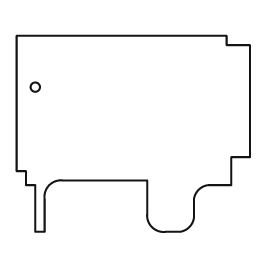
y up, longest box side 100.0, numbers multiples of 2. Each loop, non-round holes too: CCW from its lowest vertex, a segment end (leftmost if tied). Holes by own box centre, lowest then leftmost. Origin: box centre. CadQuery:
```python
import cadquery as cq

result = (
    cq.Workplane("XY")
    .moveTo(-42.0, -42.0)
    .lineTo(-38.0, -42.0)
    .lineTo(-38.0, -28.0)
    .threePointArc((-36.0, -22.0), (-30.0, -20.0))
    .lineTo(6.0, -20.0)
    .lineTo(6.0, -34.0)
    .threePointArc((8.0, -40.0), (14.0, -42.0))
    .lineTo(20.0, -42.0)
    .threePointArc((24.0, -40.0), (26.0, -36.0))
    .lineTo(26.0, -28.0)
    .threePointArc((28.0, -24.0), (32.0, -22.0))
    .lineTo(42.0, -22.0)
    .lineTo(42.0, -10.0)
    .lineTo(50.0, -10.0)
    .lineTo(50.0, 38.0)
    .lineTo(40.0, 38.0)
    .lineTo(40.0, 42.0)
    .lineTo(-50.0, 42.0)
    .lineTo(-50.0, -16.0)
    .lineTo(-46.0, -16.0)
    .lineTo(-46.0, -22.0)
    .lineTo(-42.0, -22.0)
    .close()
    .moveTo(-42.0, 20.0)
    .circle(2.0)
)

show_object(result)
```